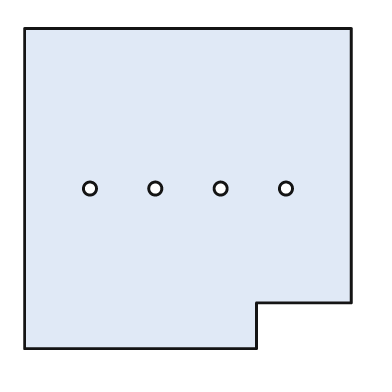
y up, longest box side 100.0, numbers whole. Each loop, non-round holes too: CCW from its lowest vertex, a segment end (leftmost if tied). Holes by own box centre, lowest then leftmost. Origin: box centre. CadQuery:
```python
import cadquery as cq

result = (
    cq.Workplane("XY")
    .moveTo(-50.0, -49.0)
    .lineTo(21.0, -49.0)
    .lineTo(21.0, -35.0)
    .lineTo(50.0, -35.0)
    .lineTo(50.0, 49.0)
    .lineTo(-50.0, 49.0)
    .close()
    .moveTo(-30.0, 0.0)
    .circle(2.0)
    .moveTo(-10.0, 0.0)
    .circle(2.0)
    .moveTo(10.0, 0.0)
    .circle(2.0)
    .moveTo(30.0, 0.0)
    .circle(2.0)
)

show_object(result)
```